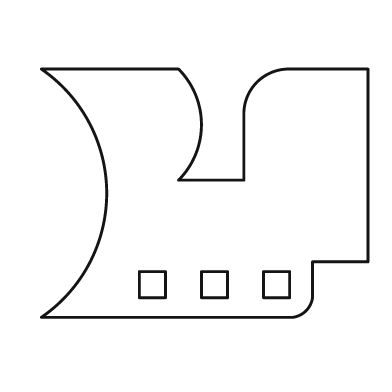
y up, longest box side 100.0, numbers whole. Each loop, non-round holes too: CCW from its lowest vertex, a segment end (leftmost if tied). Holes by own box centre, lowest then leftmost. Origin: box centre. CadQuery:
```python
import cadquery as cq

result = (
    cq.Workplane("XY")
    .moveTo(-50.0, -38.0)
    .lineTo(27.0, -38.0)
    .threePointArc((31.0, -36.0), (33.0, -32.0))
    .lineTo(33.0, -21.0)
    .lineTo(50.0, -21.0)
    .lineTo(50.0, 38.0)
    .lineTo(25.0, 38.0)
    .threePointArc((16.0, 34.0), (12.0, 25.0))
    .lineTo(12.0, 4.0)
    .lineTo(-8.0, 4.0)
    .threePointArc((-1.0, 21.0), (-8.0, 38.0))
    .lineTo(-50.0, 38.0)
    .threePointArc((-30.0, 0.0), (-50.0, -38.0))
    .close()
    .moveTo(-20.0, -32.0)
    .lineTo(-12.0, -32.0)
    .lineTo(-12.0, -24.0)
    .lineTo(-20.0, -24.0)
    .close()
    .moveTo(-1.0, -32.0)
    .lineTo(7.0, -32.0)
    .lineTo(7.0, -24.0)
    .lineTo(-1.0, -24.0)
    .close()
    .moveTo(18.0, -32.0)
    .lineTo(26.0, -32.0)
    .lineTo(26.0, -24.0)
    .lineTo(18.0, -24.0)
    .close()
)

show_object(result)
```